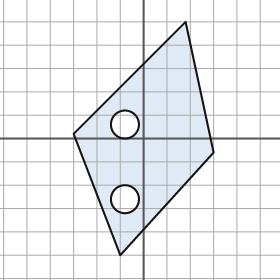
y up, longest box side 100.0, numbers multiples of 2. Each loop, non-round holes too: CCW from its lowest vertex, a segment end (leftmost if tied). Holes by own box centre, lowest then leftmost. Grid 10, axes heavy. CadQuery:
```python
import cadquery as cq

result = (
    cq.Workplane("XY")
    .moveTo(-10.0, -50.0)
    .lineTo(30.0, -6.0)
    .lineTo(18.0, 50.0)
    .lineTo(-30.0, 2.0)
    .close()
    .moveTo(-8.0, -26.0)
    .circle(6.0)
    .moveTo(-8.0, 6.0)
    .circle(6.0)
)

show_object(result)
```